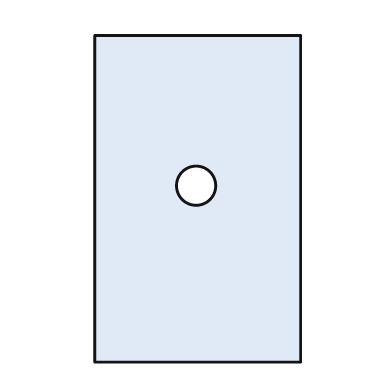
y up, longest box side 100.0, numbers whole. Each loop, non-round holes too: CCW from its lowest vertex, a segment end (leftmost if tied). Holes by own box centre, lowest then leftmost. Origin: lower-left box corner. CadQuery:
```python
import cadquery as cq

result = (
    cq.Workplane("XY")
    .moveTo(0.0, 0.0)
    .lineTo(63.0, 0.0)
    .lineTo(63.0, 100.0)
    .lineTo(0.0, 100.0)
    .close()
    .moveTo(31.0, 54.0)
    .circle(6.0)
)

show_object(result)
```